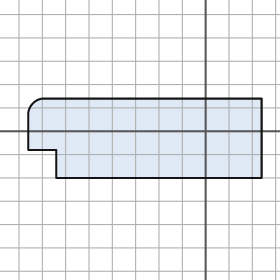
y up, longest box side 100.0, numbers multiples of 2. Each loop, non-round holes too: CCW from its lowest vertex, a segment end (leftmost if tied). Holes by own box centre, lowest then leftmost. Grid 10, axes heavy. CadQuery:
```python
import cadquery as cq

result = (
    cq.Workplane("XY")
    .moveTo(-64.0, -20.0)
    .lineTo(24.0, -20.0)
    .lineTo(24.0, 14.0)
    .lineTo(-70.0, 14.0)
    .threePointArc((-74.0, 12.0), (-76.0, 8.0))
    .lineTo(-76.0, -8.0)
    .lineTo(-64.0, -8.0)
    .close()
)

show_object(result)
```